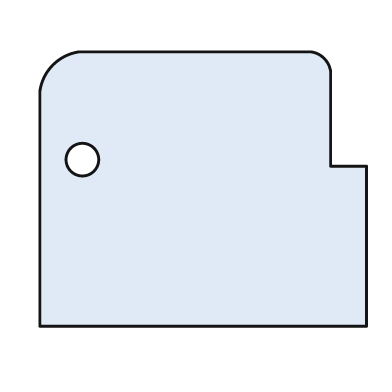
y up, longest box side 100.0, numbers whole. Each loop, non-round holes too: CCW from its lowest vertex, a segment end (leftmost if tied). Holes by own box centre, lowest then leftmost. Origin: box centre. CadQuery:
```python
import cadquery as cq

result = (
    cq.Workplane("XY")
    .moveTo(-50.0, -42.0)
    .lineTo(50.0, -42.0)
    .lineTo(50.0, 7.0)
    .lineTo(39.0, 7.0)
    .lineTo(39.0, 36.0)
    .threePointArc((37.0, 40.0), (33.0, 42.0))
    .lineTo(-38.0, 42.0)
    .threePointArc((-46.0, 38.0), (-50.0, 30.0))
    .close()
    .moveTo(-37.0, 9.0)
    .circle(5.0)
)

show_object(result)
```